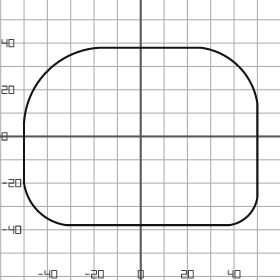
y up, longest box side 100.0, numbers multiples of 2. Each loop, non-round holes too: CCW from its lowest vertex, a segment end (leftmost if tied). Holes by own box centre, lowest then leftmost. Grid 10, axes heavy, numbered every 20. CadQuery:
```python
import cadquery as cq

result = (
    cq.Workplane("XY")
    .moveTo(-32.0, -38.0)
    .lineTo(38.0, -38.0)
    .threePointArc((46.0, -34.0), (50.0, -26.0))
    .lineTo(50.0, 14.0)
    .threePointArc((42.0, 30.0), (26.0, 38.0))
    .lineTo(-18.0, 38.0)
    .threePointArc((-40.0, 28.0), (-50.0, 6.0))
    .lineTo(-50.0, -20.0)
    .threePointArc((-44.0, -32.0), (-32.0, -38.0))
    .close()
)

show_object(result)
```